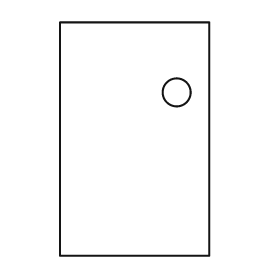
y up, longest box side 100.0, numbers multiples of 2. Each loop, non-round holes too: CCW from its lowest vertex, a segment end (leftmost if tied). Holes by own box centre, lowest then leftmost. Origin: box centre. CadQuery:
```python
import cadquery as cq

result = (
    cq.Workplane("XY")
    .moveTo(-32.0, -50.0)
    .lineTo(32.0, -50.0)
    .lineTo(32.0, 50.0)
    .lineTo(-32.0, 50.0)
    .close()
    .moveTo(18.0, 20.0)
    .circle(6.0)
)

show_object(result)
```